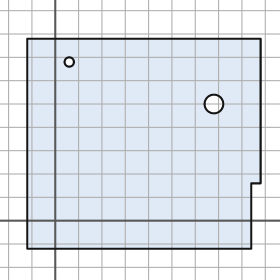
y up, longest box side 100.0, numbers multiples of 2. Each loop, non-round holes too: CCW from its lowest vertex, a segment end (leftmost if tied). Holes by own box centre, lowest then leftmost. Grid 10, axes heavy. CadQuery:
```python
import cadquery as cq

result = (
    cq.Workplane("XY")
    .moveTo(-12.0, -12.0)
    .lineTo(84.0, -12.0)
    .lineTo(84.0, 16.0)
    .lineTo(88.0, 16.0)
    .lineTo(88.0, 78.0)
    .lineTo(-12.0, 78.0)
    .close()
    .moveTo(68.0, 50.0)
    .circle(4.0)
    .moveTo(6.0, 68.0)
    .circle(2.0)
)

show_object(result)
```